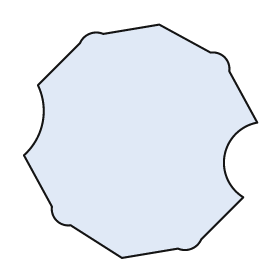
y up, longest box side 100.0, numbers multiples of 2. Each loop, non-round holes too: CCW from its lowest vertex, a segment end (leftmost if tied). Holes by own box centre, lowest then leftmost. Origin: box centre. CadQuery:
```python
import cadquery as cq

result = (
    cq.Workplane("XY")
    .moveTo(-8.0, -50.0)
    .lineTo(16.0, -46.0)
    .threePointArc((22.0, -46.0), (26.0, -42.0))
    .lineTo(44.0, -24.0)
    .threePointArc((36.0, -6.0), (50.0, 8.0))
    .lineTo(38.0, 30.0)
    .threePointArc((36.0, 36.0), (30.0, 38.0))
    .lineTo(8.0, 50.0)
    .lineTo(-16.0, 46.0)
    .threePointArc((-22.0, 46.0), (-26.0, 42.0))
    .lineTo(-44.0, 24.0)
    .threePointArc((-42.0, 8.0), (-50.0, -6.0))
    .lineTo(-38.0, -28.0)
    .threePointArc((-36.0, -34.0), (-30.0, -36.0))
    .close()
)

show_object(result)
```